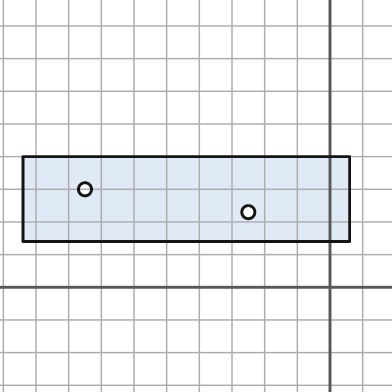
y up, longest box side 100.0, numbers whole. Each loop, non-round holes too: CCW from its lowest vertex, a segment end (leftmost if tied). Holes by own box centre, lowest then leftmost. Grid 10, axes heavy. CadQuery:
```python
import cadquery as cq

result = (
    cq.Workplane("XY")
    .moveTo(-94.0, 14.0)
    .lineTo(6.0, 14.0)
    .lineTo(6.0, 40.0)
    .lineTo(-94.0, 40.0)
    .close()
    .moveTo(-25.0, 23.0)
    .circle(2.0)
    .moveTo(-75.0, 30.0)
    .circle(2.0)
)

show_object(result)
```